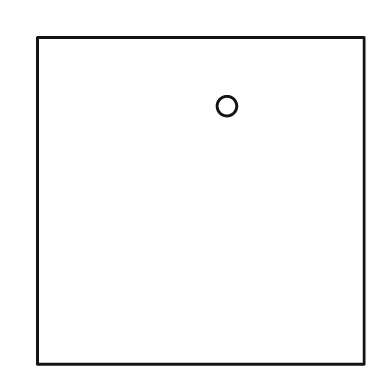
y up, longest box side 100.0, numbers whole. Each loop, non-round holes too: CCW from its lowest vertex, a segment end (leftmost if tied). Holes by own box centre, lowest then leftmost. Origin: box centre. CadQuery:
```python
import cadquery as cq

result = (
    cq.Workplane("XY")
    .moveTo(-50.0, -50.0)
    .lineTo(50.0, -50.0)
    .lineTo(50.0, 50.0)
    .lineTo(-50.0, 50.0)
    .close()
    .moveTo(8.0, 29.0)
    .circle(3.0)
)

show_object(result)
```